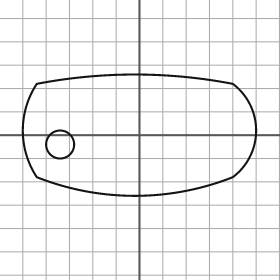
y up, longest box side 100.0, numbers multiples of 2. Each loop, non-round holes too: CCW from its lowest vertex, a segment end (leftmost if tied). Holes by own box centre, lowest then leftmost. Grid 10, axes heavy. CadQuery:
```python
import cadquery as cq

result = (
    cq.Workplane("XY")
    .moveTo(-44.0, -18.0)
    .threePointArc((-2.0, -26.0), (40.0, -18.0))
    .threePointArc((50.0, 2.0), (40.0, 22.0))
    .threePointArc((-2.0, 26.0), (-44.0, 22.0))
    .threePointArc((-50.0, 2.0), (-44.0, -18.0))
    .close()
    .moveTo(-34.0, -4.0)
    .circle(6.0)
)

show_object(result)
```